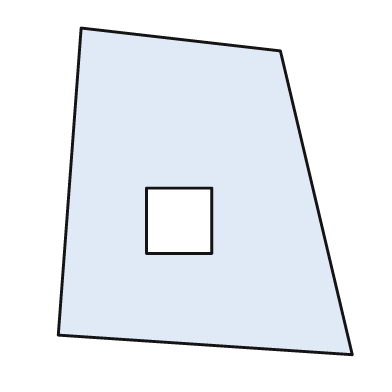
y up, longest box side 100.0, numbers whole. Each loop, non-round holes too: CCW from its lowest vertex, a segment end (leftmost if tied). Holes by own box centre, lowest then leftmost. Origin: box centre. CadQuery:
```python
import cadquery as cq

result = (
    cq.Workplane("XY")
    .moveTo(45.0, -50.0)
    .lineTo(23.0, 43.0)
    .lineTo(-38.0, 50.0)
    .lineTo(-45.0, -44.0)
    .close()
    .moveTo(-18.0, -19.0)
    .lineTo(2.0, -19.0)
    .lineTo(2.0, 1.0)
    .lineTo(-18.0, 1.0)
    .close()
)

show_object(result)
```